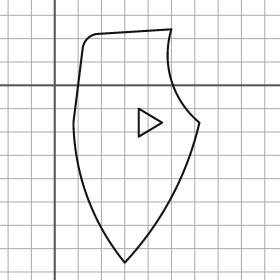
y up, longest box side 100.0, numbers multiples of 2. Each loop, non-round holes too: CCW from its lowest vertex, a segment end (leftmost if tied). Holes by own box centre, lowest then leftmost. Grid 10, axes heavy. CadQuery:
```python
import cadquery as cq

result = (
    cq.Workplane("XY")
    .moveTo(30.0, -76.0)
    .threePointArc((50.0, -48.0), (62.0, -16.0))
    .threePointArc((50.0, 2.0), (50.0, 24.0))
    .lineTo(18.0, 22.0)
    .threePointArc((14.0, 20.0), (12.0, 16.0))
    .lineTo(8.0, -16.0)
    .threePointArc((14.0, -48.0), (30.0, -76.0))
    .close()
    .moveTo(36.0, -22.0)
    .lineTo(46.0, -16.0)
    .lineTo(36.0, -10.0)
    .close()
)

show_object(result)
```